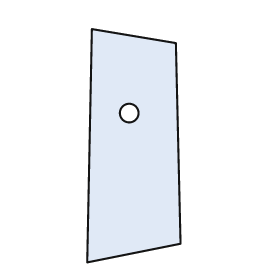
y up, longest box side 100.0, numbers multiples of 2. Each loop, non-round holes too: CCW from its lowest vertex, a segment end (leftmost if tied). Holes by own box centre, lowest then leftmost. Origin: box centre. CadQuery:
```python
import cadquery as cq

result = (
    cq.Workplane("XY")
    .moveTo(-20.0, -50.0)
    .lineTo(20.0, -42.0)
    .lineTo(18.0, 44.0)
    .lineTo(-18.0, 50.0)
    .close()
    .moveTo(-2.0, 14.0)
    .circle(4.0)
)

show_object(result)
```